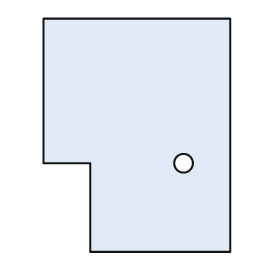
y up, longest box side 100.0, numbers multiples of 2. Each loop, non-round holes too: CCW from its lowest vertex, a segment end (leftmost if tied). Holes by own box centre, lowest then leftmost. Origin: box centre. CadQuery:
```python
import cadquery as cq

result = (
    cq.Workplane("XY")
    .moveTo(-20.0, -50.0)
    .lineTo(40.0, -50.0)
    .lineTo(40.0, 50.0)
    .lineTo(-40.0, 50.0)
    .lineTo(-40.0, -12.0)
    .lineTo(-20.0, -12.0)
    .close()
    .moveTo(20.0, -12.0)
    .circle(4.0)
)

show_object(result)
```